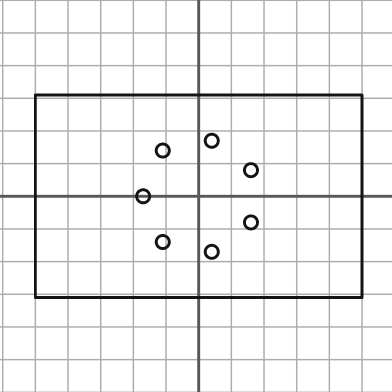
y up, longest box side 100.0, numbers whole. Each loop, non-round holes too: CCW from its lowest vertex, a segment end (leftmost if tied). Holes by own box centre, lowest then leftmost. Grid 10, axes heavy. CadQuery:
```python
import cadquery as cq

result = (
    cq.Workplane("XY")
    .moveTo(-50.0, -31.0)
    .lineTo(50.0, -31.0)
    .lineTo(50.0, 31.0)
    .lineTo(-50.0, 31.0)
    .close()
    .moveTo(4.0, -17.0)
    .circle(2.0)
    .moveTo(-11.0, -14.0)
    .circle(2.0)
    .moveTo(16.0, -8.0)
    .circle(2.0)
    .moveTo(-17.0, 0.0)
    .circle(2.0)
    .moveTo(16.0, 8.0)
    .circle(2.0)
    .moveTo(-11.0, 14.0)
    .circle(2.0)
    .moveTo(4.0, 17.0)
    .circle(2.0)
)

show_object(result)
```